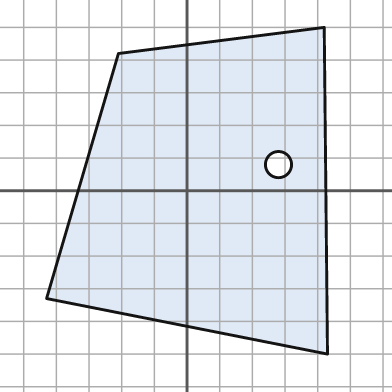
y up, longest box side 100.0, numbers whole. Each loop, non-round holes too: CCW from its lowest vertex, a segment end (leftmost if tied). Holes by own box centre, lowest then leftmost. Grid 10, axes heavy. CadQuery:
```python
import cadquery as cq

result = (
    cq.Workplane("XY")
    .moveTo(43.0, -50.0)
    .lineTo(42.0, 50.0)
    .lineTo(-21.0, 42.0)
    .lineTo(-43.0, -33.0)
    .close()
    .moveTo(28.0, 8.0)
    .circle(4.0)
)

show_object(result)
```